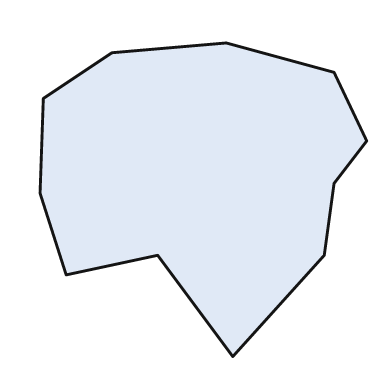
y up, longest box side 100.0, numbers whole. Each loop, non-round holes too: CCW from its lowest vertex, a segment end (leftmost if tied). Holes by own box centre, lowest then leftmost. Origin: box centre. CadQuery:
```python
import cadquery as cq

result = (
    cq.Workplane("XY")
    .moveTo(9.0, -48.0)
    .lineTo(37.0, -17.0)
    .lineTo(40.0, 5.0)
    .lineTo(50.0, 18.0)
    .lineTo(40.0, 39.0)
    .lineTo(7.0, 48.0)
    .lineTo(-28.0, 45.0)
    .lineTo(-49.0, 31.0)
    .lineTo(-50.0, 2.0)
    .lineTo(-42.0, -23.0)
    .lineTo(-14.0, -17.0)
    .close()
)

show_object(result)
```